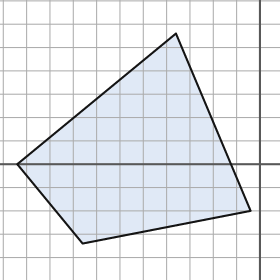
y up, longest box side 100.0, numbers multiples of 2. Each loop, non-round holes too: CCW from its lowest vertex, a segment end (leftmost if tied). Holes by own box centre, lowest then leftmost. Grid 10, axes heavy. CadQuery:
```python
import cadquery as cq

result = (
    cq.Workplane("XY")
    .moveTo(-76.0, -34.0)
    .lineTo(-4.0, -20.0)
    .lineTo(-36.0, 56.0)
    .lineTo(-104.0, 0.0)
    .close()
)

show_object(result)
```